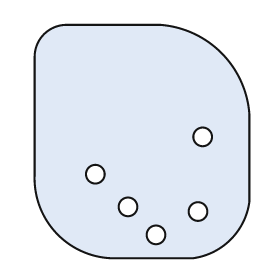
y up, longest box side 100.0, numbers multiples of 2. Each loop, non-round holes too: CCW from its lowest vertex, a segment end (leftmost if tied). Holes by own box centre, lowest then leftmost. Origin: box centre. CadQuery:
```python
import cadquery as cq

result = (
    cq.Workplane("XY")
    .moveTo(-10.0, -50.0)
    .lineTo(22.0, -50.0)
    .threePointArc((38.0, -42.0), (46.0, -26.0))
    .lineTo(46.0, 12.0)
    .threePointArc((34.0, 38.0), (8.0, 50.0))
    .lineTo(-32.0, 50.0)
    .threePointArc((-42.0, 46.0), (-46.0, 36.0))
    .lineTo(-46.0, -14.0)
    .threePointArc((-36.0, -40.0), (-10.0, -50.0))
    .close()
    .moveTo(6.0, -40.0)
    .circle(4.0)
    .moveTo(24.0, -30.0)
    .circle(4.0)
    .moveTo(-6.0, -28.0)
    .circle(4.0)
    .moveTo(-20.0, -14.0)
    .circle(4.0)
    .moveTo(26.0, 2.0)
    .circle(4.0)
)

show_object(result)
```